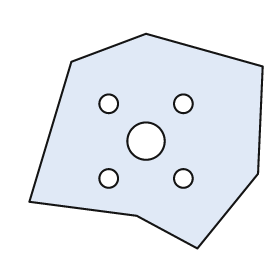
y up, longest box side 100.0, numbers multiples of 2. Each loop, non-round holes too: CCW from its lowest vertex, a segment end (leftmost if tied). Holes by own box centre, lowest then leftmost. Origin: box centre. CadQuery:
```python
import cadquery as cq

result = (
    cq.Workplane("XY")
    .moveTo(22.0, -46.0)
    .lineTo(48.0, -14.0)
    .lineTo(50.0, 32.0)
    .lineTo(0.0, 46.0)
    .lineTo(-32.0, 34.0)
    .lineTo(-50.0, -26.0)
    .lineTo(-4.0, -32.0)
    .close()
    .moveTo(-16.0, -16.0)
    .circle(4.0)
    .moveTo(16.0, -16.0)
    .circle(4.0)
    .moveTo(0.0, 0.0)
    .circle(8.0)
    .moveTo(-16.0, 16.0)
    .circle(4.0)
    .moveTo(16.0, 16.0)
    .circle(4.0)
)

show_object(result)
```